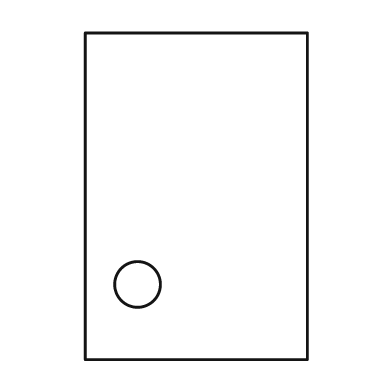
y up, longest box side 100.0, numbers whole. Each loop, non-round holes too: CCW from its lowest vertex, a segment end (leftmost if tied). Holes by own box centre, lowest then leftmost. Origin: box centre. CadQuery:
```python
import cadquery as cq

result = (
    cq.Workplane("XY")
    .moveTo(-34.0, -50.0)
    .lineTo(34.0, -50.0)
    .lineTo(34.0, 50.0)
    .lineTo(-34.0, 50.0)
    .close()
    .moveTo(-18.0, -27.0)
    .circle(7.0)
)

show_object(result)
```